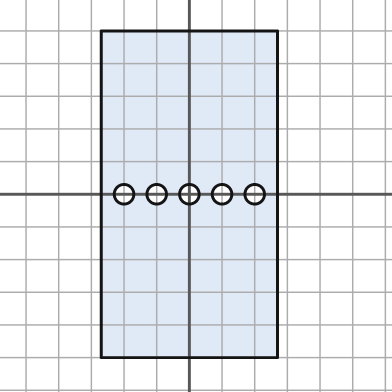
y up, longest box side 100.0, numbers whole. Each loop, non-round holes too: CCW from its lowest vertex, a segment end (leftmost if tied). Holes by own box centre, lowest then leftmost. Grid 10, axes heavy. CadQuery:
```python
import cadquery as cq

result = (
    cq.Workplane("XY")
    .moveTo(-27.0, -50.0)
    .lineTo(27.0, -50.0)
    .lineTo(27.0, 50.0)
    .lineTo(-27.0, 50.0)
    .close()
    .moveTo(-20.0, 0.0)
    .circle(3.0)
    .moveTo(-10.0, 0.0)
    .circle(3.0)
    .moveTo(0.0, 0.0)
    .circle(3.0)
    .moveTo(10.0, 0.0)
    .circle(3.0)
    .moveTo(20.0, 0.0)
    .circle(3.0)
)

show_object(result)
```